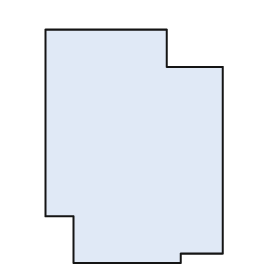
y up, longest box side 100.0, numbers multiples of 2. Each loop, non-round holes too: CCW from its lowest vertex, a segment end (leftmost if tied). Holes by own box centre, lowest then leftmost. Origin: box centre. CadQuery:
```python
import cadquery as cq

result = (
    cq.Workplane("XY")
    .moveTo(-26.0, -50.0)
    .lineTo(20.0, -50.0)
    .lineTo(20.0, -46.0)
    .lineTo(38.0, -46.0)
    .lineTo(38.0, 34.0)
    .lineTo(14.0, 34.0)
    .lineTo(14.0, 50.0)
    .lineTo(-38.0, 50.0)
    .lineTo(-38.0, -30.0)
    .lineTo(-26.0, -30.0)
    .close()
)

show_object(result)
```